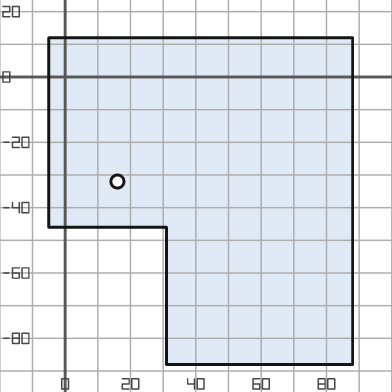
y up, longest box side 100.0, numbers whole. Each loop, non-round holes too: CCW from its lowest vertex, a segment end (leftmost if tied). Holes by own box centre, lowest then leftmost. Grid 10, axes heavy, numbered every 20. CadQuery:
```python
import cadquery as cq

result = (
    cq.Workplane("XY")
    .moveTo(31.0, -88.0)
    .lineTo(88.0, -88.0)
    .lineTo(88.0, 12.0)
    .lineTo(-5.0, 12.0)
    .lineTo(-5.0, -46.0)
    .lineTo(31.0, -46.0)
    .close()
    .moveTo(16.0, -32.0)
    .circle(2.0)
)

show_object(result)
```